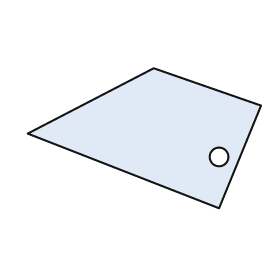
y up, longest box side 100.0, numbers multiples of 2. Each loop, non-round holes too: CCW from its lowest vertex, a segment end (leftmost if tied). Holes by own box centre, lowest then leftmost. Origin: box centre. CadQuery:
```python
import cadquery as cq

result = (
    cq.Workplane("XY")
    .moveTo(32.0, -30.0)
    .lineTo(50.0, 14.0)
    .lineTo(4.0, 30.0)
    .lineTo(-50.0, 2.0)
    .close()
    .moveTo(32.0, -8.0)
    .circle(4.0)
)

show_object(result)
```